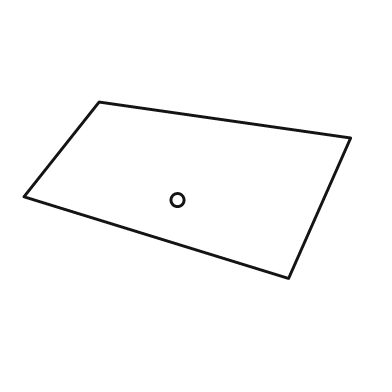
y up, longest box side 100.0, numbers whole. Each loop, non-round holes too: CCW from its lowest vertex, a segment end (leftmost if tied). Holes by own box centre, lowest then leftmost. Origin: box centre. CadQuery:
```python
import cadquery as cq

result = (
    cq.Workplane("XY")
    .moveTo(31.0, -27.0)
    .lineTo(50.0, 16.0)
    .lineTo(-27.0, 27.0)
    .lineTo(-50.0, -2.0)
    .close()
    .moveTo(-3.0, -3.0)
    .circle(2.0)
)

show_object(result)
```